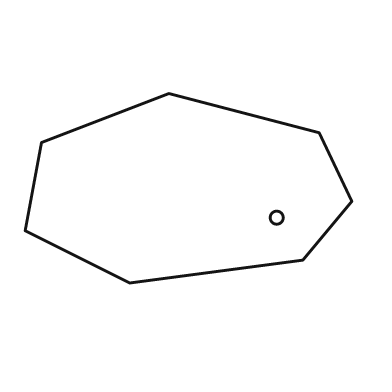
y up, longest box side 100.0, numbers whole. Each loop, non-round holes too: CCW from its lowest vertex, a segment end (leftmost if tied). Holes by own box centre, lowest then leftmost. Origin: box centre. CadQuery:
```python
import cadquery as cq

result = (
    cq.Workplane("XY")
    .moveTo(-18.0, -29.0)
    .lineTo(35.0, -22.0)
    .lineTo(50.0, -4.0)
    .lineTo(40.0, 17.0)
    .lineTo(-6.0, 29.0)
    .lineTo(-45.0, 14.0)
    .lineTo(-50.0, -13.0)
    .close()
    .moveTo(27.0, -9.0)
    .circle(2.0)
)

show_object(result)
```